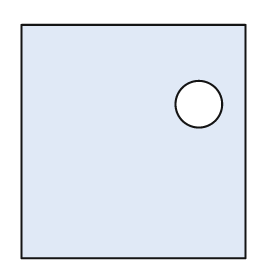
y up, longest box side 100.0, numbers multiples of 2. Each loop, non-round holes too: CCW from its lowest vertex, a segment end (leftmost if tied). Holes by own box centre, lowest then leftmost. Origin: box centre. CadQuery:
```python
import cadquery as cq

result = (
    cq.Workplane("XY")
    .moveTo(-48.0, -50.0)
    .lineTo(48.0, -50.0)
    .lineTo(48.0, 50.0)
    .lineTo(-48.0, 50.0)
    .close()
    .moveTo(28.0, 16.0)
    .circle(10.0)
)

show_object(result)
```